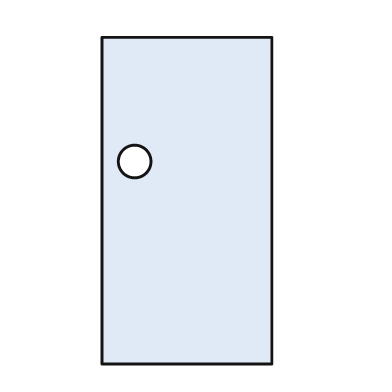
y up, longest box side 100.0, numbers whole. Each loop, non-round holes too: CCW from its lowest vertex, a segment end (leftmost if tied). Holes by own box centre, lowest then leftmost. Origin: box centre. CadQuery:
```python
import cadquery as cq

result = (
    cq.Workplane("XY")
    .moveTo(-26.0, -50.0)
    .lineTo(26.0, -50.0)
    .lineTo(26.0, 50.0)
    .lineTo(-26.0, 50.0)
    .close()
    .moveTo(-16.0, 12.0)
    .circle(5.0)
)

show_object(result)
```